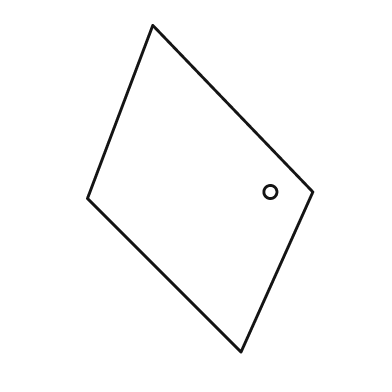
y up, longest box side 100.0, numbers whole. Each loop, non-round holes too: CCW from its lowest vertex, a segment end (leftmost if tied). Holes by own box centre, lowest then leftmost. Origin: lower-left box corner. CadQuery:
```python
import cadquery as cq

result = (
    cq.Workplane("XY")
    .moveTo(47.0, 0.0)
    .lineTo(69.0, 49.0)
    .lineTo(20.0, 100.0)
    .lineTo(0.0, 47.0)
    .close()
    .moveTo(56.0, 49.0)
    .circle(2.0)
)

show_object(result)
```